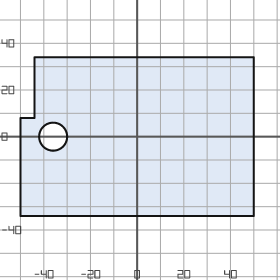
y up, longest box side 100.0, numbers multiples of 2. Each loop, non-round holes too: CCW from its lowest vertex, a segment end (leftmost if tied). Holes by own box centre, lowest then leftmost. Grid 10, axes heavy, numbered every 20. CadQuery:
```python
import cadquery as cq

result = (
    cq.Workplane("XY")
    .moveTo(-50.0, -34.0)
    .lineTo(50.0, -34.0)
    .lineTo(50.0, 34.0)
    .lineTo(-44.0, 34.0)
    .lineTo(-44.0, 8.0)
    .lineTo(-50.0, 8.0)
    .close()
    .moveTo(-36.0, 0.0)
    .circle(6.0)
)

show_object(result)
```